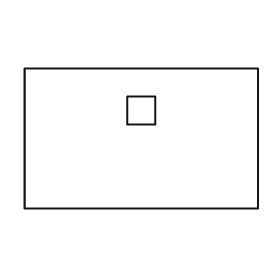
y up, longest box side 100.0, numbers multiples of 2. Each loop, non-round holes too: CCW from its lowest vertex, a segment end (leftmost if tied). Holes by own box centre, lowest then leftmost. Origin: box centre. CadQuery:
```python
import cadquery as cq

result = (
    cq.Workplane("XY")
    .moveTo(-50.0, -30.0)
    .lineTo(50.0, -30.0)
    .lineTo(50.0, 30.0)
    .lineTo(-50.0, 30.0)
    .close()
    .moveTo(-6.0, 6.0)
    .lineTo(6.0, 6.0)
    .lineTo(6.0, 18.0)
    .lineTo(-6.0, 18.0)
    .close()
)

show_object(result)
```